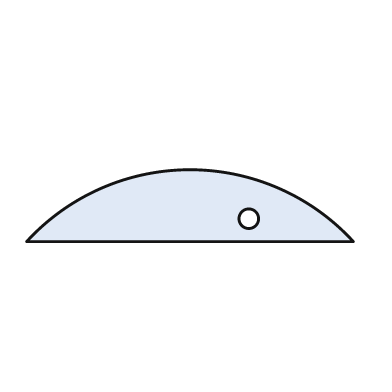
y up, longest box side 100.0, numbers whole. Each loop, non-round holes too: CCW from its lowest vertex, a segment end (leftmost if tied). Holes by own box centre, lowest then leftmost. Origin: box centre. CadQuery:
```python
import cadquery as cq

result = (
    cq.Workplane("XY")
    .moveTo(-50.0, -11.0)
    .lineTo(50.0, -11.0)
    .threePointArc((0.0, 11.0), (-50.0, -11.0))
    .close()
    .moveTo(18.0, -4.0)
    .circle(3.0)
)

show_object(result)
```